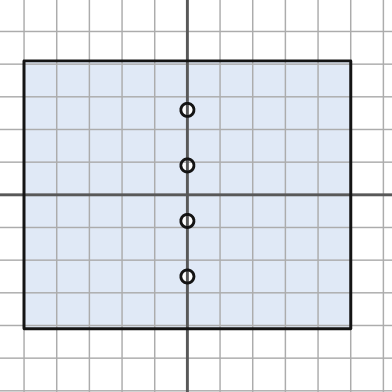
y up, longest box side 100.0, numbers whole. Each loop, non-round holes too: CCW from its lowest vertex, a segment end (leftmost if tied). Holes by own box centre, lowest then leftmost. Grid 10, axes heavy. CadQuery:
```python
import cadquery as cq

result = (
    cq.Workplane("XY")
    .moveTo(-50.0, -41.0)
    .lineTo(50.0, -41.0)
    .lineTo(50.0, 41.0)
    .lineTo(-50.0, 41.0)
    .close()
    .moveTo(0.0, -25.0)
    .circle(2.0)
    .moveTo(0.0, -8.0)
    .circle(2.0)
    .moveTo(0.0, 9.0)
    .circle(2.0)
    .moveTo(0.0, 26.0)
    .circle(2.0)
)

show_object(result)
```